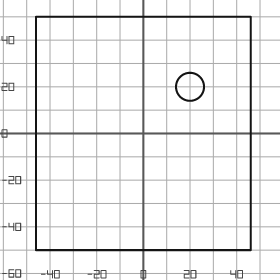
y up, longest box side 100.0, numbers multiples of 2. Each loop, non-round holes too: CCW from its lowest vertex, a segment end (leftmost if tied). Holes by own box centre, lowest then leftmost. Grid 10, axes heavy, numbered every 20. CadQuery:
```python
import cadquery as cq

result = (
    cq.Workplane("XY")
    .moveTo(-46.0, -50.0)
    .lineTo(46.0, -50.0)
    .lineTo(46.0, 50.0)
    .lineTo(-46.0, 50.0)
    .close()
    .moveTo(20.0, 20.0)
    .circle(6.0)
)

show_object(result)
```